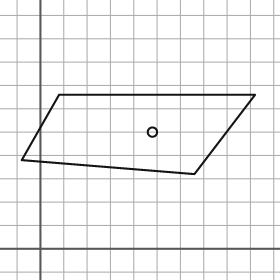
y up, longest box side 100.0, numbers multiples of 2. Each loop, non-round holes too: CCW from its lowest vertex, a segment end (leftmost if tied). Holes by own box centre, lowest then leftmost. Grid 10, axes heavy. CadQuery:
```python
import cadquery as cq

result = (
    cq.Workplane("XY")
    .moveTo(66.0, 32.0)
    .lineTo(92.0, 66.0)
    .lineTo(8.0, 66.0)
    .lineTo(-8.0, 38.0)
    .close()
    .moveTo(48.0, 50.0)
    .circle(2.0)
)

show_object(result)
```